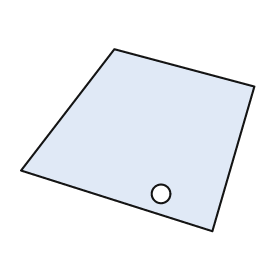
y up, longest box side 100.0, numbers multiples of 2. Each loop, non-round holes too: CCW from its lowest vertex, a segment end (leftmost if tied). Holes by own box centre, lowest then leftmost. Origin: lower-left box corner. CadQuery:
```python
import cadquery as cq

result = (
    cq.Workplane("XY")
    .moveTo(82.0, 0.0)
    .lineTo(100.0, 62.0)
    .lineTo(40.0, 78.0)
    .lineTo(0.0, 26.0)
    .close()
    .moveTo(60.0, 16.0)
    .circle(4.0)
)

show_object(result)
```